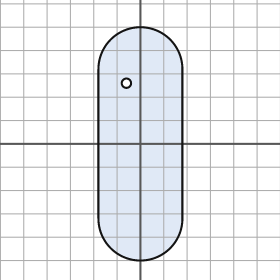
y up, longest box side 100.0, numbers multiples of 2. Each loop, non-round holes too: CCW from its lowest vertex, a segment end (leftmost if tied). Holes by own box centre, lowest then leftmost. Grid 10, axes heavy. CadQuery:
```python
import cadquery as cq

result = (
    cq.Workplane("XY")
    .moveTo(-18.0, -32.0)
    .threePointArc((0.0, -50.0), (18.0, -32.0))
    .lineTo(18.0, 32.0)
    .threePointArc((0.0, 50.0), (-18.0, 32.0))
    .close()
    .moveTo(-6.0, 26.0)
    .circle(2.0)
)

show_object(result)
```